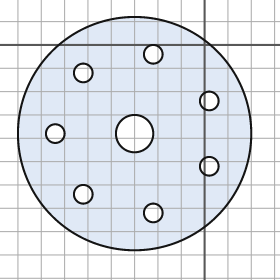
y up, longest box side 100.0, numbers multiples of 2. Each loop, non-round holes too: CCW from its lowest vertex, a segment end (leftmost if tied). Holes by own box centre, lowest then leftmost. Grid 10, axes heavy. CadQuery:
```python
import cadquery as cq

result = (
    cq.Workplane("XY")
    .moveTo(-30.0, -38.0)
    .circle(50.0)
    .moveTo(-22.0, -72.0)
    .circle(4.0)
    .moveTo(-52.0, -64.0)
    .circle(4.0)
    .moveTo(2.0, -52.0)
    .circle(4.0)
    .moveTo(-64.0, -38.0)
    .circle(4.0)
    .moveTo(-30.0, -38.0)
    .circle(8.0)
    .moveTo(2.0, -24.0)
    .circle(4.0)
    .moveTo(-52.0, -12.0)
    .circle(4.0)
    .moveTo(-22.0, -4.0)
    .circle(4.0)
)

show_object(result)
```